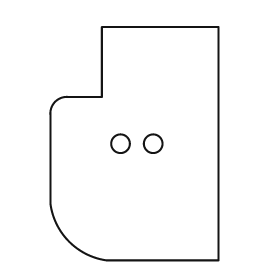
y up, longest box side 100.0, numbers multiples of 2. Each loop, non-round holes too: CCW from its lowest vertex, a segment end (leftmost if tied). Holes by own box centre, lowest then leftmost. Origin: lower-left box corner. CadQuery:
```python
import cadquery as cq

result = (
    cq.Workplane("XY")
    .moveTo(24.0, 0.0)
    .lineTo(72.0, 0.0)
    .lineTo(72.0, 100.0)
    .lineTo(22.0, 100.0)
    .lineTo(22.0, 70.0)
    .lineTo(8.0, 70.0)
    .threePointArc((2.0, 68.0), (0.0, 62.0))
    .lineTo(0.0, 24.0)
    .threePointArc((8.0, 8.0), (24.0, 0.0))
    .close()
    .moveTo(30.0, 50.0)
    .circle(4.0)
    .moveTo(44.0, 50.0)
    .circle(4.0)
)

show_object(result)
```